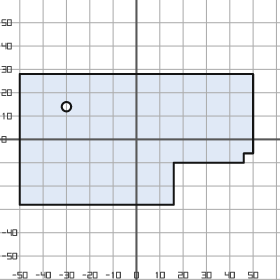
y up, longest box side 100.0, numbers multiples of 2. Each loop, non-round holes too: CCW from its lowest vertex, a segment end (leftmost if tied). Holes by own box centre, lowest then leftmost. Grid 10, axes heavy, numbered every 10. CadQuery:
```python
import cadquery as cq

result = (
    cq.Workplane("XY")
    .moveTo(-50.0, -28.0)
    .lineTo(16.0, -28.0)
    .lineTo(16.0, -10.0)
    .lineTo(46.0, -10.0)
    .lineTo(46.0, -6.0)
    .lineTo(50.0, -6.0)
    .lineTo(50.0, 28.0)
    .lineTo(-50.0, 28.0)
    .close()
    .moveTo(-30.0, 14.0)
    .circle(2.0)
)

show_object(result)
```